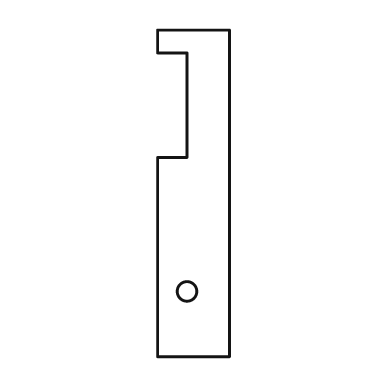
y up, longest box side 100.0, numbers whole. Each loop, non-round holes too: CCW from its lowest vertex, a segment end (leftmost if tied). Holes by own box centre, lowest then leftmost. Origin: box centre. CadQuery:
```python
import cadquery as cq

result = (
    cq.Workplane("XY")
    .moveTo(-11.0, -50.0)
    .lineTo(11.0, -50.0)
    .lineTo(11.0, 50.0)
    .lineTo(-11.0, 50.0)
    .lineTo(-11.0, 43.0)
    .lineTo(-2.0, 43.0)
    .lineTo(-2.0, 11.0)
    .lineTo(-11.0, 11.0)
    .close()
    .moveTo(-2.0, -30.0)
    .circle(3.0)
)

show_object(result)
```